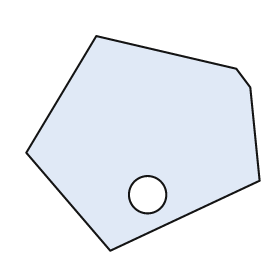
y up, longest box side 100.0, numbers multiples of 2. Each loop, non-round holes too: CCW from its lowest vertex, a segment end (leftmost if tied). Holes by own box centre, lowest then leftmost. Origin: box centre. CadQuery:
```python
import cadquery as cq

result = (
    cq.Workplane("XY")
    .moveTo(-14.0, -46.0)
    .lineTo(50.0, -16.0)
    .lineTo(46.0, 24.0)
    .lineTo(40.0, 32.0)
    .lineTo(-20.0, 46.0)
    .lineTo(-50.0, -4.0)
    .close()
    .moveTo(2.0, -22.0)
    .circle(8.0)
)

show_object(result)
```